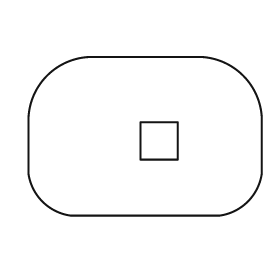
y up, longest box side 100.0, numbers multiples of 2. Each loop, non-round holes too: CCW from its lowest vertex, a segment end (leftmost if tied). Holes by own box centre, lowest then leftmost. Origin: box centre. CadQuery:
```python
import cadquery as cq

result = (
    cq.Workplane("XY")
    .moveTo(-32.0, -34.0)
    .lineTo(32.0, -34.0)
    .threePointArc((44.0, -28.0), (50.0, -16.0))
    .lineTo(50.0, 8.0)
    .threePointArc((42.0, 26.0), (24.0, 34.0))
    .lineTo(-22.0, 34.0)
    .threePointArc((-42.0, 26.0), (-50.0, 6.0))
    .lineTo(-50.0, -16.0)
    .threePointArc((-44.0, -28.0), (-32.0, -34.0))
    .close()
    .moveTo(-2.0, -10.0)
    .lineTo(14.0, -10.0)
    .lineTo(14.0, 6.0)
    .lineTo(-2.0, 6.0)
    .close()
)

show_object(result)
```